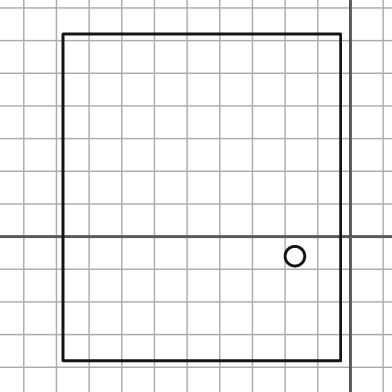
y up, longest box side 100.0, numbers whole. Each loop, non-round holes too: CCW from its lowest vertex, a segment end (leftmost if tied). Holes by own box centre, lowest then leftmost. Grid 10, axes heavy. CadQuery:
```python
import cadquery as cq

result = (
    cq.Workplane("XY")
    .moveTo(-88.0, -38.0)
    .lineTo(-3.0, -38.0)
    .lineTo(-3.0, 62.0)
    .lineTo(-88.0, 62.0)
    .close()
    .moveTo(-17.0, -6.0)
    .circle(3.0)
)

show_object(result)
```